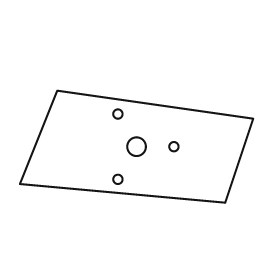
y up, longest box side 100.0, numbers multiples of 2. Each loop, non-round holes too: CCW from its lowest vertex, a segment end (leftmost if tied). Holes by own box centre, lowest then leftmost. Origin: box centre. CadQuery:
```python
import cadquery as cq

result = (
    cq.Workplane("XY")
    .moveTo(38.0, -24.0)
    .lineTo(50.0, 12.0)
    .lineTo(-34.0, 24.0)
    .lineTo(-50.0, -16.0)
    .close()
    .moveTo(-8.0, -14.0)
    .circle(2.0)
    .moveTo(0.0, 0.0)
    .circle(4.0)
    .moveTo(16.0, 0.0)
    .circle(2.0)
    .moveTo(-8.0, 14.0)
    .circle(2.0)
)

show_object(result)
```